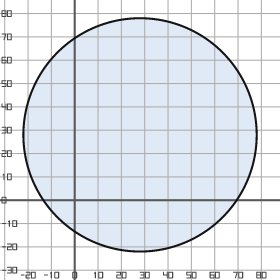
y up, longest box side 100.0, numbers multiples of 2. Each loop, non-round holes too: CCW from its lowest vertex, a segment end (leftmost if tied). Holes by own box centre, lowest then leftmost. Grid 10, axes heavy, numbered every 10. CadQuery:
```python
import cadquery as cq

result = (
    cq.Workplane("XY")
    .moveTo(28.0, 28.0)
    .circle(50.0)
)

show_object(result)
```